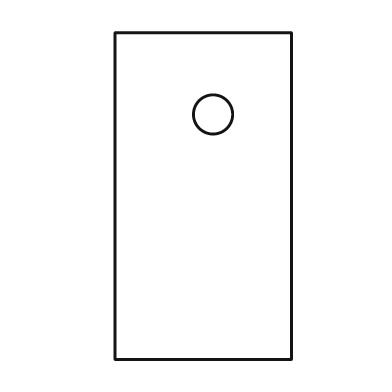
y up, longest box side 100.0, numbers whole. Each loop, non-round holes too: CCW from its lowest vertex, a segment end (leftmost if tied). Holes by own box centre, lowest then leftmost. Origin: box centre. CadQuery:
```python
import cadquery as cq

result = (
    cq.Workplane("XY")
    .moveTo(-27.0, -50.0)
    .lineTo(27.0, -50.0)
    .lineTo(27.0, 50.0)
    .lineTo(-27.0, 50.0)
    .close()
    .moveTo(3.0, 25.0)
    .circle(6.0)
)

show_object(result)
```